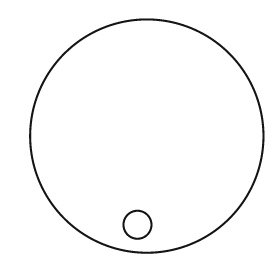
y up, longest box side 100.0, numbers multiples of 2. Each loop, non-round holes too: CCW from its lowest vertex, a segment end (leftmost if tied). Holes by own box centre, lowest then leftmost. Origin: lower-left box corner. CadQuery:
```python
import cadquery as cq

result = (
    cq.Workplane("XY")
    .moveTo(50.0, 50.0)
    .circle(50.0)
    .moveTo(46.0, 12.0)
    .circle(6.0)
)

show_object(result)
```